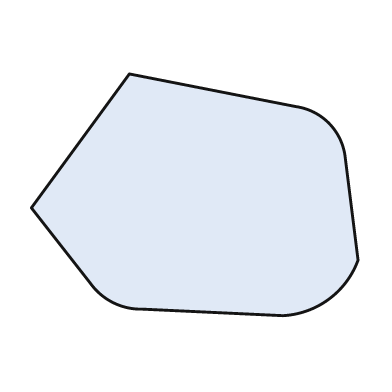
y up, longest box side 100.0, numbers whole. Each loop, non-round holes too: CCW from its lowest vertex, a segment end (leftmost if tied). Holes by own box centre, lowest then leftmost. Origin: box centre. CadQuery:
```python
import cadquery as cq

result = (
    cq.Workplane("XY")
    .moveTo(27.0, -37.0)
    .threePointArc((41.0, -32.0), (50.0, -20.0))
    .lineTo(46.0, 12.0)
    .threePointArc((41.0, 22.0), (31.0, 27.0))
    .lineTo(-20.0, 37.0)
    .lineTo(-50.0, -4.0)
    .lineTo(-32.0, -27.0)
    .threePointArc((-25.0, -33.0), (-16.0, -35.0))
    .close()
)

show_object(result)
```